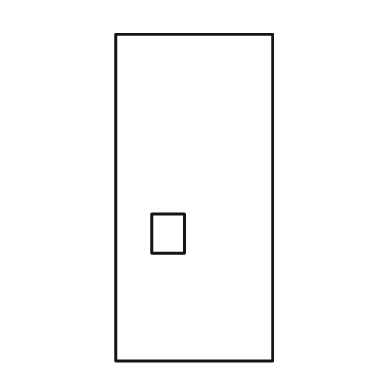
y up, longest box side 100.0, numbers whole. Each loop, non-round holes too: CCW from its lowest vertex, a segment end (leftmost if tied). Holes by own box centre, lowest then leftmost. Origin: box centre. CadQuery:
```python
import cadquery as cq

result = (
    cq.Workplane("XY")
    .moveTo(-24.0, -50.0)
    .lineTo(24.0, -50.0)
    .lineTo(24.0, 50.0)
    .lineTo(-24.0, 50.0)
    .close()
    .moveTo(-13.0, -17.0)
    .lineTo(-3.0, -17.0)
    .lineTo(-3.0, -5.0)
    .lineTo(-13.0, -5.0)
    .close()
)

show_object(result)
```